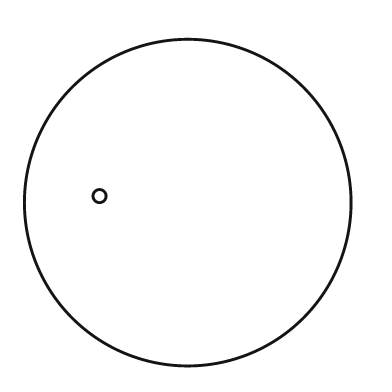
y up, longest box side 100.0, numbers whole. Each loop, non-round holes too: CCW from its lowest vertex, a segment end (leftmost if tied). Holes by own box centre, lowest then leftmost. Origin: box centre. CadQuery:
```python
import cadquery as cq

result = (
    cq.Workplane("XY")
    .moveTo(0.0, 0.0)
    .circle(50.0)
    .moveTo(-27.0, 2.0)
    .circle(2.0)
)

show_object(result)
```